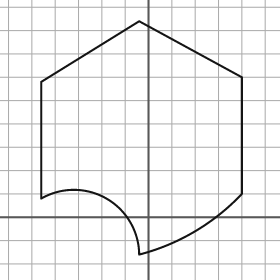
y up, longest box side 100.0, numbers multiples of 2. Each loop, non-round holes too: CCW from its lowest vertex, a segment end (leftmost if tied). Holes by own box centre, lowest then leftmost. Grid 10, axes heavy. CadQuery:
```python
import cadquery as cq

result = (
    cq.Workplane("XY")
    .moveTo(-4.0, -16.0)
    .threePointArc((20.0, -6.0), (40.0, 10.0))
    .lineTo(40.0, 60.0)
    .lineTo(-4.0, 84.0)
    .lineTo(-46.0, 58.0)
    .lineTo(-46.0, 8.0)
    .threePointArc((-18.0, 8.0), (-4.0, -16.0))
    .close()
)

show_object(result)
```